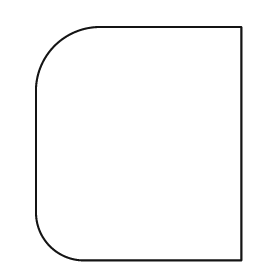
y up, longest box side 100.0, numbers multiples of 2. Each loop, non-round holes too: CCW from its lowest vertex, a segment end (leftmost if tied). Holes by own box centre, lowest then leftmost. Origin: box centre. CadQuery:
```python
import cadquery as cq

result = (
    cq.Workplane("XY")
    .moveTo(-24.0, -50.0)
    .lineTo(44.0, -50.0)
    .lineTo(44.0, 50.0)
    .lineTo(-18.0, 50.0)
    .threePointArc((-36.0, 42.0), (-44.0, 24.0))
    .lineTo(-44.0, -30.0)
    .threePointArc((-38.0, -44.0), (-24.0, -50.0))
    .close()
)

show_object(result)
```